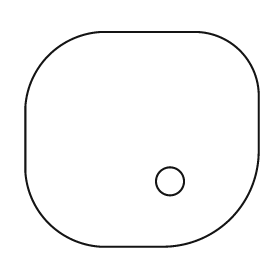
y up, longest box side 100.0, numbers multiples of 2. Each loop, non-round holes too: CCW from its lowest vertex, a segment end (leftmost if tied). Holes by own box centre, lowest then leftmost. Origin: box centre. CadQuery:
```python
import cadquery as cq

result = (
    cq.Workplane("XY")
    .moveTo(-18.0, -46.0)
    .lineTo(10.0, -46.0)
    .threePointArc((38.0, -34.0), (50.0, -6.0))
    .lineTo(50.0, 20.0)
    .threePointArc((42.0, 38.0), (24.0, 46.0))
    .lineTo(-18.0, 46.0)
    .threePointArc((-40.0, 36.0), (-50.0, 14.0))
    .lineTo(-50.0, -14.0)
    .threePointArc((-40.0, -36.0), (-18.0, -46.0))
    .close()
    .moveTo(12.0, -18.0)
    .circle(6.0)
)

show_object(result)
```